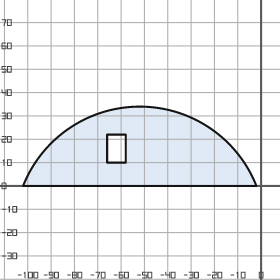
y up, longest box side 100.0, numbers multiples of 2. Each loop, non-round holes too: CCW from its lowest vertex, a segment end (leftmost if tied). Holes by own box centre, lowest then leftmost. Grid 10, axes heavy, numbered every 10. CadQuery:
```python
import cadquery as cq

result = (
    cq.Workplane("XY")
    .moveTo(-102.0, 0.0)
    .lineTo(-2.0, 0.0)
    .threePointArc((-52.0, 34.0), (-102.0, 0.0))
    .close()
    .moveTo(-66.0, 10.0)
    .lineTo(-58.0, 10.0)
    .lineTo(-58.0, 22.0)
    .lineTo(-66.0, 22.0)
    .close()
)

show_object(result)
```